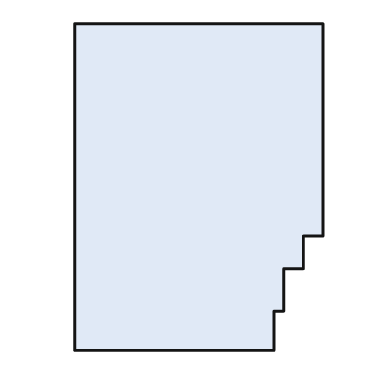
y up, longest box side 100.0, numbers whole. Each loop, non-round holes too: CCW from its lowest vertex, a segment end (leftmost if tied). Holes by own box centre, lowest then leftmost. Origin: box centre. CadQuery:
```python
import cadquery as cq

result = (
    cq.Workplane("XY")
    .moveTo(-38.0, -50.0)
    .lineTo(23.0, -50.0)
    .lineTo(23.0, -38.0)
    .lineTo(26.0, -38.0)
    .lineTo(26.0, -25.0)
    .lineTo(32.0, -25.0)
    .lineTo(32.0, -15.0)
    .lineTo(38.0, -15.0)
    .lineTo(38.0, 50.0)
    .lineTo(-38.0, 50.0)
    .close()
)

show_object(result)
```